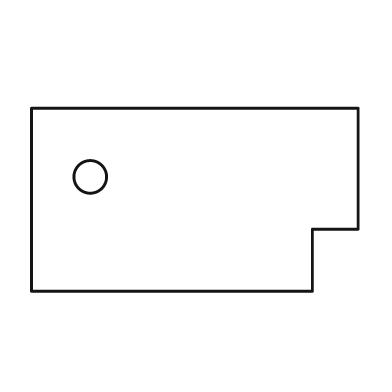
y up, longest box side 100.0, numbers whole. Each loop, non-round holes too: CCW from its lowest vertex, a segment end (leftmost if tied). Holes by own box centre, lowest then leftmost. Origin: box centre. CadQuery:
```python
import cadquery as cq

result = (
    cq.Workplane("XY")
    .moveTo(-50.0, -28.0)
    .lineTo(36.0, -28.0)
    .lineTo(36.0, -9.0)
    .lineTo(50.0, -9.0)
    .lineTo(50.0, 28.0)
    .lineTo(-50.0, 28.0)
    .close()
    .moveTo(-32.0, 7.0)
    .circle(5.0)
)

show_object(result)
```